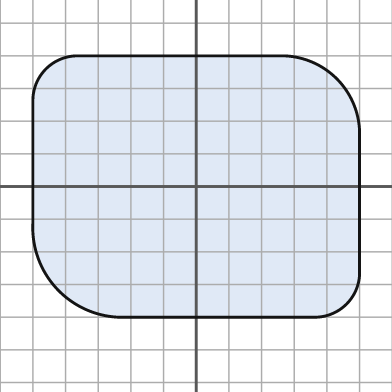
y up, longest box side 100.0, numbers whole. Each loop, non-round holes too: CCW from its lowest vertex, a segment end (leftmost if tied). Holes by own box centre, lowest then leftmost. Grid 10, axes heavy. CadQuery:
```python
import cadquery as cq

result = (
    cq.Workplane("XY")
    .moveTo(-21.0, -40.0)
    .lineTo(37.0, -40.0)
    .threePointArc((46.0, -36.0), (50.0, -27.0))
    .lineTo(50.0, 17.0)
    .threePointArc((43.0, 33.0), (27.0, 40.0))
    .lineTo(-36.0, 40.0)
    .threePointArc((-46.0, 36.0), (-50.0, 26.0))
    .lineTo(-50.0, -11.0)
    .threePointArc((-42.0, -32.0), (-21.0, -40.0))
    .close()
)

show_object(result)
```